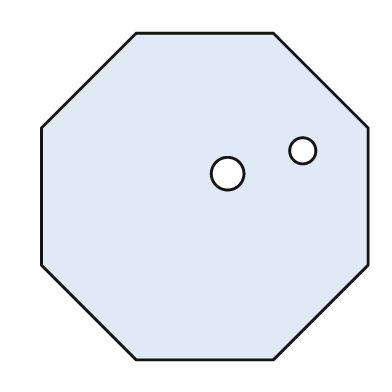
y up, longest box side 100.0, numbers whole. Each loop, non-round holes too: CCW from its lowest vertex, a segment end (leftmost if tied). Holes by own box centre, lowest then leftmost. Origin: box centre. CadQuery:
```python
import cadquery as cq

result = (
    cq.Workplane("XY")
    .moveTo(-21.0, -50.0)
    .lineTo(21.0, -50.0)
    .lineTo(50.0, -21.0)
    .lineTo(50.0, 21.0)
    .lineTo(21.0, 50.0)
    .lineTo(-21.0, 50.0)
    .lineTo(-50.0, 21.0)
    .lineTo(-50.0, -21.0)
    .close()
    .moveTo(7.0, 7.0)
    .circle(5.0)
    .moveTo(30.0, 14.0)
    .circle(4.0)
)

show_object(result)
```